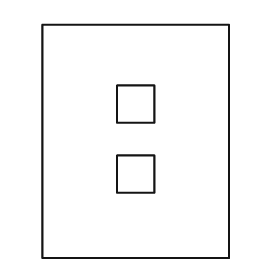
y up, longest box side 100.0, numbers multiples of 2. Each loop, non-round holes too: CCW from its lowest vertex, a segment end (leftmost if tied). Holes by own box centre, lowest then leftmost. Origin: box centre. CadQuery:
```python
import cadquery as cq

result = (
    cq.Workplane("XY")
    .moveTo(-40.0, -50.0)
    .lineTo(40.0, -50.0)
    .lineTo(40.0, 50.0)
    .lineTo(-40.0, 50.0)
    .close()
    .moveTo(-8.0, -22.0)
    .lineTo(8.0, -22.0)
    .lineTo(8.0, -6.0)
    .lineTo(-8.0, -6.0)
    .close()
    .moveTo(-8.0, 8.0)
    .lineTo(8.0, 8.0)
    .lineTo(8.0, 24.0)
    .lineTo(-8.0, 24.0)
    .close()
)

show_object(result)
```